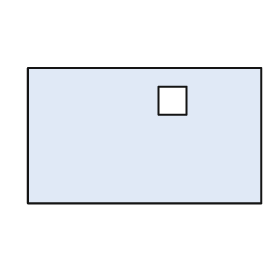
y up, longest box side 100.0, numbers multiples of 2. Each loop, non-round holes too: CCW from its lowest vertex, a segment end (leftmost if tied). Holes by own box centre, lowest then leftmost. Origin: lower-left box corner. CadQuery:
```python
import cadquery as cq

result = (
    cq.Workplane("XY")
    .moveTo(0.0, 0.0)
    .lineTo(100.0, 0.0)
    .lineTo(100.0, 58.0)
    .lineTo(0.0, 58.0)
    .close()
    .moveTo(56.0, 38.0)
    .lineTo(68.0, 38.0)
    .lineTo(68.0, 50.0)
    .lineTo(56.0, 50.0)
    .close()
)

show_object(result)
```